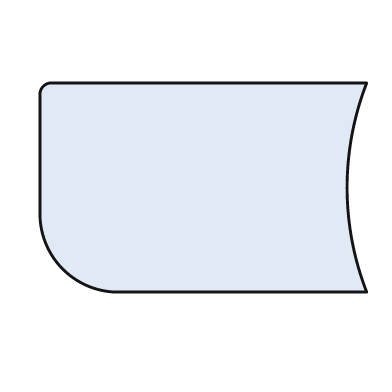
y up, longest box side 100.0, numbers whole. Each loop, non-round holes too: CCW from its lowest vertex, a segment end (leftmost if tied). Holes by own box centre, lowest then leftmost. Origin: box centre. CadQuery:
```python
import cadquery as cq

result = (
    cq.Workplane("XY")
    .moveTo(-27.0, -32.0)
    .lineTo(50.0, -32.0)
    .threePointArc((44.0, 0.0), (50.0, 32.0))
    .lineTo(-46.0, 32.0)
    .threePointArc((-49.0, 31.0), (-50.0, 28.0))
    .lineTo(-50.0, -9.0)
    .threePointArc((-43.0, -25.0), (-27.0, -32.0))
    .close()
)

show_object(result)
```